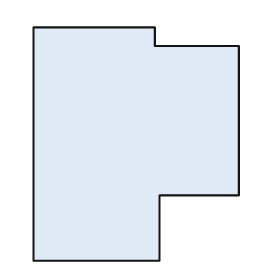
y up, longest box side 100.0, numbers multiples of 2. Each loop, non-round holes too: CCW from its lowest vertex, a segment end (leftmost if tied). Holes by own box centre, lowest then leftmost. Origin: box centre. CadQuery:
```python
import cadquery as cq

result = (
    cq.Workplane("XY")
    .moveTo(-44.0, -50.0)
    .lineTo(10.0, -50.0)
    .lineTo(10.0, -22.0)
    .lineTo(44.0, -22.0)
    .lineTo(44.0, 42.0)
    .lineTo(8.0, 42.0)
    .lineTo(8.0, 50.0)
    .lineTo(-44.0, 50.0)
    .close()
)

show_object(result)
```